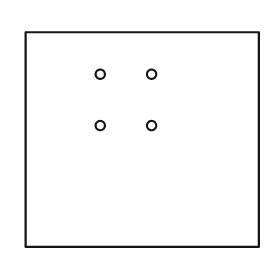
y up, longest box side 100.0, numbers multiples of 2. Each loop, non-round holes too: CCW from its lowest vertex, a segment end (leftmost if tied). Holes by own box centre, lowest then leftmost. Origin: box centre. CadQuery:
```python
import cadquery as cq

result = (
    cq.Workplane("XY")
    .moveTo(-50.0, -46.0)
    .lineTo(50.0, -46.0)
    .lineTo(50.0, 46.0)
    .lineTo(-50.0, 46.0)
    .close()
    .moveTo(-18.0, 6.0)
    .circle(2.0)
    .moveTo(4.0, 6.0)
    .circle(2.0)
    .moveTo(-18.0, 28.0)
    .circle(2.0)
    .moveTo(4.0, 28.0)
    .circle(2.0)
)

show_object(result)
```